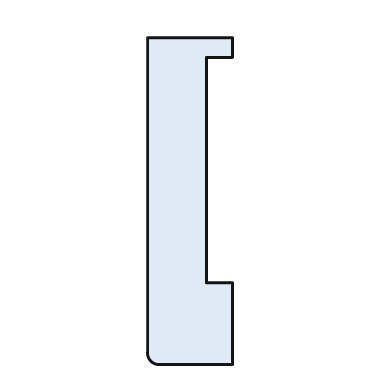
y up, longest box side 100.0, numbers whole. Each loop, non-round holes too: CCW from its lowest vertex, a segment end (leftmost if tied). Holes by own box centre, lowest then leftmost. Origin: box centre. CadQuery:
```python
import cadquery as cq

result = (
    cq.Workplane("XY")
    .moveTo(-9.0, -50.0)
    .lineTo(13.0, -50.0)
    .lineTo(13.0, -25.0)
    .lineTo(5.0, -25.0)
    .lineTo(5.0, 44.0)
    .lineTo(13.0, 44.0)
    .lineTo(13.0, 50.0)
    .lineTo(-13.0, 50.0)
    .lineTo(-13.0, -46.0)
    .threePointArc((-12.0, -49.0), (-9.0, -50.0))
    .close()
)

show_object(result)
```